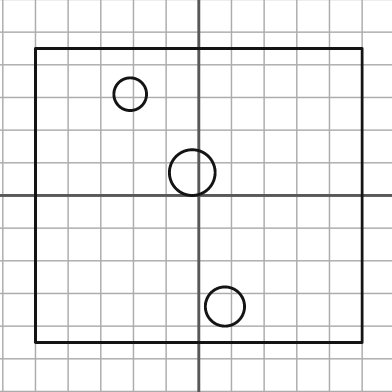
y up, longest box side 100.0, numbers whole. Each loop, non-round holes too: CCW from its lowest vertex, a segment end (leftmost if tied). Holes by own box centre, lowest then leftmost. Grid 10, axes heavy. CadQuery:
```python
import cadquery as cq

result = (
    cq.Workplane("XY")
    .moveTo(-50.0, -45.0)
    .lineTo(50.0, -45.0)
    .lineTo(50.0, 45.0)
    .lineTo(-50.0, 45.0)
    .close()
    .moveTo(8.0, -34.0)
    .circle(6.0)
    .moveTo(-2.0, 7.0)
    .circle(7.0)
    .moveTo(-21.0, 31.0)
    .circle(5.0)
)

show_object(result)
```